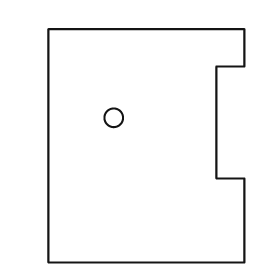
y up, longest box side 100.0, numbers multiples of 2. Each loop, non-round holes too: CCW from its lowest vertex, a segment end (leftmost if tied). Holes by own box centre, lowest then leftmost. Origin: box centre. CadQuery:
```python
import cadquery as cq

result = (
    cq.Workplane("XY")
    .moveTo(-42.0, -50.0)
    .lineTo(42.0, -50.0)
    .lineTo(42.0, -14.0)
    .lineTo(30.0, -14.0)
    .lineTo(30.0, 34.0)
    .lineTo(42.0, 34.0)
    .lineTo(42.0, 50.0)
    .lineTo(-42.0, 50.0)
    .close()
    .moveTo(-14.0, 12.0)
    .circle(4.0)
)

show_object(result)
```